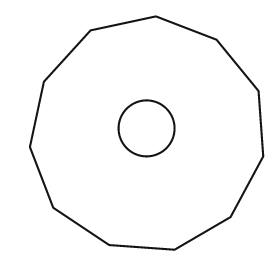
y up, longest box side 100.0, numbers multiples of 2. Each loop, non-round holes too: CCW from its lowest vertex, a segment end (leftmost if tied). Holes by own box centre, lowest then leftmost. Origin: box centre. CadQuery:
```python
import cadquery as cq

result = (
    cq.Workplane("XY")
    .moveTo(12.0, -50.0)
    .lineTo(36.0, -36.0)
    .lineTo(50.0, -10.0)
    .lineTo(48.0, 18.0)
    .lineTo(30.0, 40.0)
    .lineTo(4.0, 50.0)
    .lineTo(-24.0, 44.0)
    .lineTo(-44.0, 22.0)
    .lineTo(-50.0, -6.0)
    .lineTo(-40.0, -32.0)
    .lineTo(-16.0, -48.0)
    .close()
    .moveTo(0.0, 2.0)
    .circle(12.0)
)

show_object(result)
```